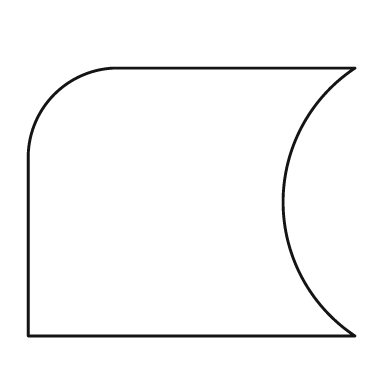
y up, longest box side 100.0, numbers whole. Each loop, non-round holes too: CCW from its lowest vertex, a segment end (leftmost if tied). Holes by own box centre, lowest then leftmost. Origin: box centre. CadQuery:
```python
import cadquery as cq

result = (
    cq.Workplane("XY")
    .moveTo(-50.0, -41.0)
    .lineTo(50.0, -41.0)
    .threePointArc((28.0, 0.0), (50.0, 41.0))
    .lineTo(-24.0, 41.0)
    .threePointArc((-42.0, 33.0), (-50.0, 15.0))
    .close()
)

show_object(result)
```